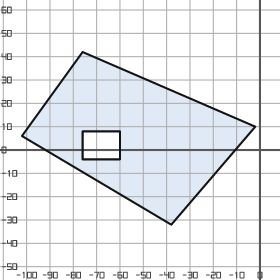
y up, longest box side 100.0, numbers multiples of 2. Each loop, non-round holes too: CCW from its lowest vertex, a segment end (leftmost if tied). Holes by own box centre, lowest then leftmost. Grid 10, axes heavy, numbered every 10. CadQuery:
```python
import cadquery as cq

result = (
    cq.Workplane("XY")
    .moveTo(-38.0, -32.0)
    .lineTo(-2.0, 10.0)
    .lineTo(-76.0, 42.0)
    .lineTo(-102.0, 6.0)
    .close()
    .moveTo(-76.0, -4.0)
    .lineTo(-60.0, -4.0)
    .lineTo(-60.0, 8.0)
    .lineTo(-76.0, 8.0)
    .close()
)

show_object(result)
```